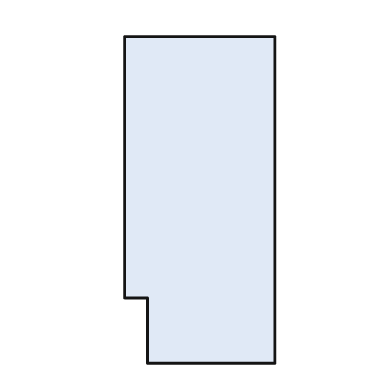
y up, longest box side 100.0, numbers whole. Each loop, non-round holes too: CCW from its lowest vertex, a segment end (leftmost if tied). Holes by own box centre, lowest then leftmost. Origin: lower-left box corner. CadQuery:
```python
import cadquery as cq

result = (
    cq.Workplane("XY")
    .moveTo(7.0, 0.0)
    .lineTo(46.0, 0.0)
    .lineTo(46.0, 100.0)
    .lineTo(0.0, 100.0)
    .lineTo(0.0, 20.0)
    .lineTo(7.0, 20.0)
    .close()
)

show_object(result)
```